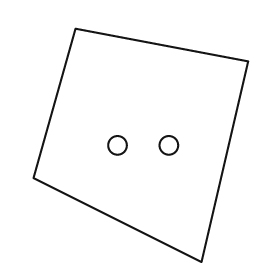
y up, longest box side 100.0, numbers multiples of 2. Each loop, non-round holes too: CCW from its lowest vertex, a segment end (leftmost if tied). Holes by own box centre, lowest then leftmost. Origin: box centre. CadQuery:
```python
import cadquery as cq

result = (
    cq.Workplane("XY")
    .moveTo(26.0, -50.0)
    .lineTo(46.0, 36.0)
    .lineTo(-28.0, 50.0)
    .lineTo(-46.0, -14.0)
    .close()
    .moveTo(-10.0, 0.0)
    .circle(4.0)
    .moveTo(12.0, 0.0)
    .circle(4.0)
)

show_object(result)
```